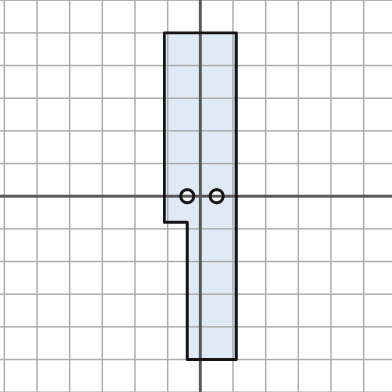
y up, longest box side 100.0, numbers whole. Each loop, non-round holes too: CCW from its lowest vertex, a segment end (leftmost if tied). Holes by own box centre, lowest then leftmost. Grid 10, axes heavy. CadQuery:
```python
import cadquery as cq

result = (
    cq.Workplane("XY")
    .moveTo(-4.0, -50.0)
    .lineTo(11.0, -50.0)
    .lineTo(11.0, 50.0)
    .lineTo(-11.0, 50.0)
    .lineTo(-11.0, -8.0)
    .lineTo(-4.0, -8.0)
    .close()
    .moveTo(-4.0, 0.0)
    .circle(2.0)
    .moveTo(5.0, 0.0)
    .circle(2.0)
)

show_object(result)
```